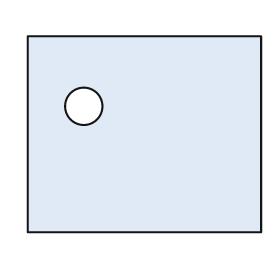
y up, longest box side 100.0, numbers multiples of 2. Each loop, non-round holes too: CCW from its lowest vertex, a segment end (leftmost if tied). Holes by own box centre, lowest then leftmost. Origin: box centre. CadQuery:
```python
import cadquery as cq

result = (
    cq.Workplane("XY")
    .moveTo(-50.0, -42.0)
    .lineTo(50.0, -42.0)
    .lineTo(50.0, 42.0)
    .lineTo(-50.0, 42.0)
    .close()
    .moveTo(-26.0, 12.0)
    .circle(8.0)
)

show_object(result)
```